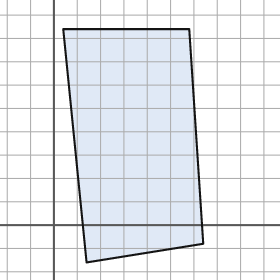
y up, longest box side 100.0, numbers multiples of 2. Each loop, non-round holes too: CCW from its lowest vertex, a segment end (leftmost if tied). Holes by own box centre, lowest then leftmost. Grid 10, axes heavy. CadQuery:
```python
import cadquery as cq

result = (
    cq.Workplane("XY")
    .moveTo(14.0, -16.0)
    .lineTo(64.0, -8.0)
    .lineTo(58.0, 84.0)
    .lineTo(4.0, 84.0)
    .close()
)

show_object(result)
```